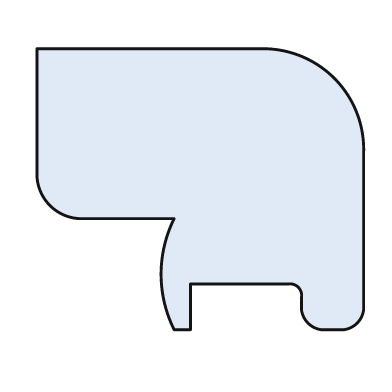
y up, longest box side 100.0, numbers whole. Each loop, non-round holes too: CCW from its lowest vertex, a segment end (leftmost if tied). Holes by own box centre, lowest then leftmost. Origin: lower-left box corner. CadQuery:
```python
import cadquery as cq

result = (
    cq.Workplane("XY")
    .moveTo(42.0, 0.0)
    .lineTo(47.0, 0.0)
    .lineTo(47.0, 14.0)
    .lineTo(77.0, 14.0)
    .threePointArc((80.0, 13.0), (81.0, 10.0))
    .lineTo(81.0, 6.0)
    .threePointArc((83.0, 2.0), (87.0, 0.0))
    .lineTo(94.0, 0.0)
    .threePointArc((98.0, 2.0), (100.0, 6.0))
    .lineTo(100.0, 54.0)
    .threePointArc((91.0, 77.0), (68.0, 86.0))
    .lineTo(0.0, 86.0)
    .lineTo(0.0, 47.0)
    .threePointArc((4.0, 38.0), (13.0, 34.0))
    .lineTo(42.0, 34.0)
    .threePointArc((38.0, 17.0), (42.0, 0.0))
    .close()
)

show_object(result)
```